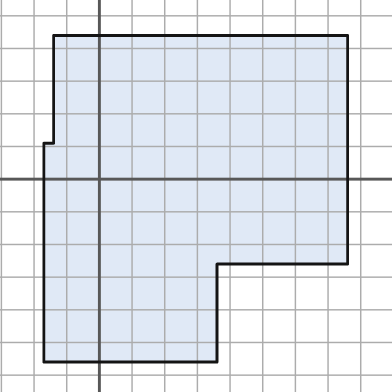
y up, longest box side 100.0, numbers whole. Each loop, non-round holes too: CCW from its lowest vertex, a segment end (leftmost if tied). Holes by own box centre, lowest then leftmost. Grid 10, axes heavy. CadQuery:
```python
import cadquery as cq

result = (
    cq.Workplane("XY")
    .moveTo(-17.0, -56.0)
    .lineTo(36.0, -56.0)
    .lineTo(36.0, -26.0)
    .lineTo(76.0, -26.0)
    .lineTo(76.0, 44.0)
    .lineTo(-14.0, 44.0)
    .lineTo(-14.0, 11.0)
    .lineTo(-17.0, 11.0)
    .close()
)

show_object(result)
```